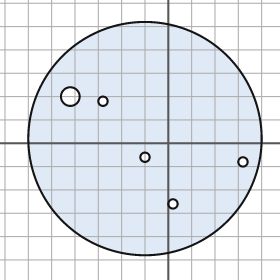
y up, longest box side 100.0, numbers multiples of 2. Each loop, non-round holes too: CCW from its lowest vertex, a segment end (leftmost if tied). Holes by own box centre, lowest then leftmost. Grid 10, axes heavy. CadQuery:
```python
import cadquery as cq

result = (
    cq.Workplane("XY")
    .moveTo(-10.0, 2.0)
    .circle(50.0)
    .moveTo(2.0, -26.0)
    .circle(2.0)
    .moveTo(32.0, -8.0)
    .circle(2.0)
    .moveTo(-10.0, -6.0)
    .circle(2.0)
    .moveTo(-28.0, 18.0)
    .circle(2.0)
    .moveTo(-42.0, 20.0)
    .circle(4.0)
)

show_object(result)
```